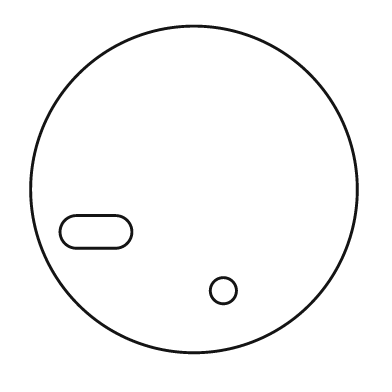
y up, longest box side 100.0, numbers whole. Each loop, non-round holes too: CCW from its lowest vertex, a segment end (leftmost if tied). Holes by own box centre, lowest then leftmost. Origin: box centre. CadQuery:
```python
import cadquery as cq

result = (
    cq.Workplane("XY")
    .moveTo(0.0, 0.0)
    .circle(50.0)
    .moveTo(9.0, -31.0)
    .circle(4.0)
    .moveTo(-36.0, -18.0)
    .lineTo(-24.0, -18.0)
    .threePointArc((-19.0, -13.0), (-24.0, -8.0))
    .lineTo(-36.0, -8.0)
    .threePointArc((-41.0, -13.0), (-36.0, -18.0))
    .close()
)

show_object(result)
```